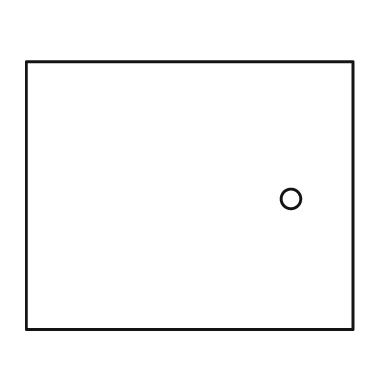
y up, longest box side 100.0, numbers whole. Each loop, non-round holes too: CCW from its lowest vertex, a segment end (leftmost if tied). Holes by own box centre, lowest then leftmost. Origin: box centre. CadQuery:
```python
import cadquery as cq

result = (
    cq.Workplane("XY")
    .moveTo(-50.0, -41.0)
    .lineTo(50.0, -41.0)
    .lineTo(50.0, 41.0)
    .lineTo(-50.0, 41.0)
    .close()
    .moveTo(31.0, -1.0)
    .circle(3.0)
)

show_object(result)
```